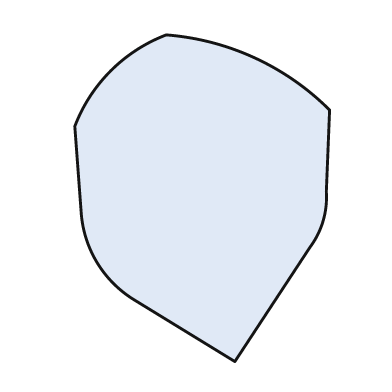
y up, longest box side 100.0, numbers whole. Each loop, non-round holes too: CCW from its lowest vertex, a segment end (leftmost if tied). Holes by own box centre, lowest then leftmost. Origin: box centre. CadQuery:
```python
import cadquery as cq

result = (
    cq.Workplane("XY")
    .moveTo(10.0, -50.0)
    .lineTo(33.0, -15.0)
    .threePointArc((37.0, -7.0), (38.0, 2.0))
    .lineTo(39.0, 27.0)
    .threePointArc((16.0, 43.0), (-11.0, 50.0))
    .threePointArc((-28.0, 39.0), (-39.0, 22.0))
    .lineTo(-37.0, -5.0)
    .threePointArc((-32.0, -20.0), (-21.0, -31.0))
    .close()
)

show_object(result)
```